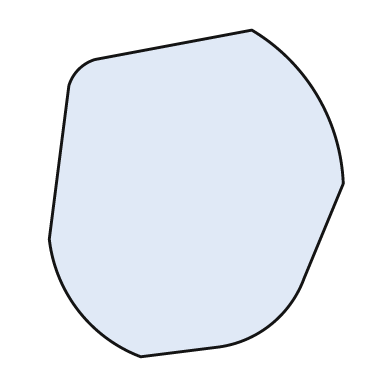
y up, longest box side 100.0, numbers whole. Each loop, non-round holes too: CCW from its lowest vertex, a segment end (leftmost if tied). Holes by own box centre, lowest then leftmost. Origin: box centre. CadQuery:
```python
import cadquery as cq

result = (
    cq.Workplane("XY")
    .moveTo(-17.0, -50.0)
    .lineTo(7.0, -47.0)
    .threePointArc((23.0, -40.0), (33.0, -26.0))
    .lineTo(45.0, 3.0)
    .threePointArc((37.0, 30.0), (17.0, 50.0))
    .lineTo(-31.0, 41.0)
    .threePointArc((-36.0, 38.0), (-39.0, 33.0))
    .lineTo(-45.0, -14.0)
    .threePointArc((-36.0, -36.0), (-17.0, -50.0))
    .close()
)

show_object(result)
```